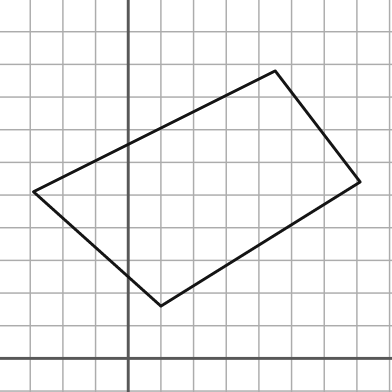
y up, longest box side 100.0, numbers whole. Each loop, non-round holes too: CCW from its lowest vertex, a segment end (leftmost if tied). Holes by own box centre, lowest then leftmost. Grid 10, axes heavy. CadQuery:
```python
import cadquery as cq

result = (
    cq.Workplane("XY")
    .moveTo(10.0, 16.0)
    .lineTo(71.0, 54.0)
    .lineTo(45.0, 88.0)
    .lineTo(-29.0, 51.0)
    .close()
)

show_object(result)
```